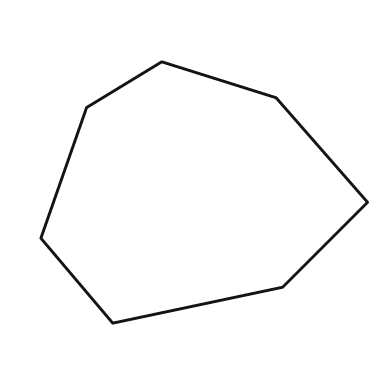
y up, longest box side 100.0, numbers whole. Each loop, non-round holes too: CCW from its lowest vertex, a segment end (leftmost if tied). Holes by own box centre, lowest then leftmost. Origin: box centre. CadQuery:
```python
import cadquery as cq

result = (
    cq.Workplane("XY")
    .moveTo(-28.0, -40.0)
    .lineTo(24.0, -29.0)
    .lineTo(50.0, -3.0)
    .lineTo(22.0, 29.0)
    .lineTo(-13.0, 40.0)
    .lineTo(-36.0, 26.0)
    .lineTo(-50.0, -14.0)
    .close()
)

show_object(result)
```